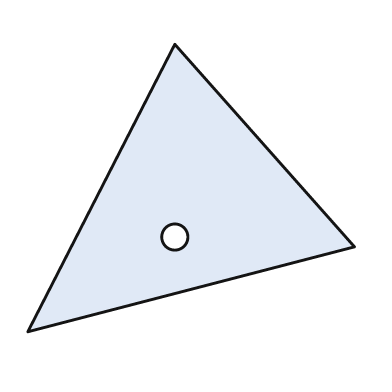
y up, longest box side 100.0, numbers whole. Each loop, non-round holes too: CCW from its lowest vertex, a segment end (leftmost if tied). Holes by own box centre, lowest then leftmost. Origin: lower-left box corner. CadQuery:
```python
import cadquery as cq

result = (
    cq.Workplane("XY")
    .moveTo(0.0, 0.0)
    .lineTo(100.0, 26.0)
    .lineTo(45.0, 88.0)
    .close()
    .moveTo(45.0, 29.0)
    .circle(4.0)
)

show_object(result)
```